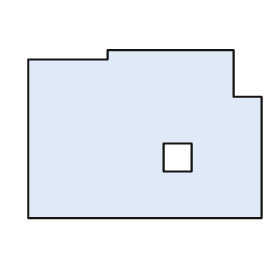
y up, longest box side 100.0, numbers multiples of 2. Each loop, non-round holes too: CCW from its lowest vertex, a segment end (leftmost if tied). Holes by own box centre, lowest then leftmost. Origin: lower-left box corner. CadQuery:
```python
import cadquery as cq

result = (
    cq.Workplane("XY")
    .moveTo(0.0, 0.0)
    .lineTo(100.0, 0.0)
    .lineTo(100.0, 52.0)
    .lineTo(88.0, 52.0)
    .lineTo(88.0, 72.0)
    .lineTo(34.0, 72.0)
    .lineTo(34.0, 68.0)
    .lineTo(0.0, 68.0)
    .close()
    .moveTo(58.0, 20.0)
    .lineTo(70.0, 20.0)
    .lineTo(70.0, 32.0)
    .lineTo(58.0, 32.0)
    .close()
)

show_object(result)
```